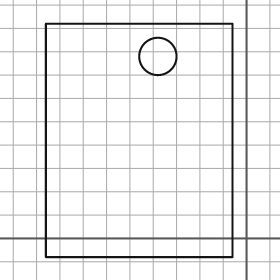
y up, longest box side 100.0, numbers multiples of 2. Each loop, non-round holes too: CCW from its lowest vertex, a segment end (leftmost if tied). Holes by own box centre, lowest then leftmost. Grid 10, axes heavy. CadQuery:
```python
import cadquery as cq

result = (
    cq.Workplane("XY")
    .moveTo(-86.0, -8.0)
    .lineTo(-6.0, -8.0)
    .lineTo(-6.0, 92.0)
    .lineTo(-86.0, 92.0)
    .close()
    .moveTo(-38.0, 78.0)
    .circle(8.0)
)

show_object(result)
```